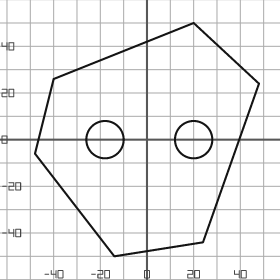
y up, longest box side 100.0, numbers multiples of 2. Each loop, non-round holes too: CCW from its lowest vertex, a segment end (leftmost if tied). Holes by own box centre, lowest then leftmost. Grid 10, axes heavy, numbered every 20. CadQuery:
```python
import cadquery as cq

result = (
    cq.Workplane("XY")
    .moveTo(-14.0, -50.0)
    .lineTo(24.0, -44.0)
    .lineTo(48.0, 24.0)
    .lineTo(20.0, 50.0)
    .lineTo(-40.0, 26.0)
    .lineTo(-48.0, -6.0)
    .close()
    .moveTo(-18.0, 0.0)
    .circle(8.0)
    .moveTo(20.0, 0.0)
    .circle(8.0)
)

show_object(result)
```